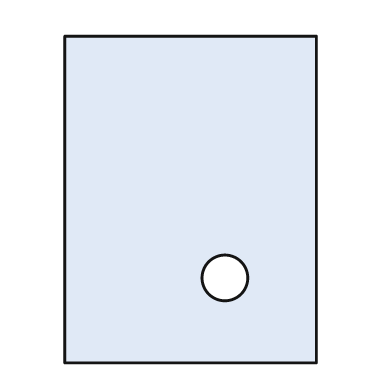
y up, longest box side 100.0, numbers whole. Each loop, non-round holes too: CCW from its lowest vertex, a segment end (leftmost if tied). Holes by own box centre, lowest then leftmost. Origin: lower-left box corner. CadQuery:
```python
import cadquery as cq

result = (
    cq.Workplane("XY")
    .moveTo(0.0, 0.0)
    .lineTo(77.0, 0.0)
    .lineTo(77.0, 100.0)
    .lineTo(0.0, 100.0)
    .close()
    .moveTo(49.0, 26.0)
    .circle(7.0)
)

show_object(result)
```